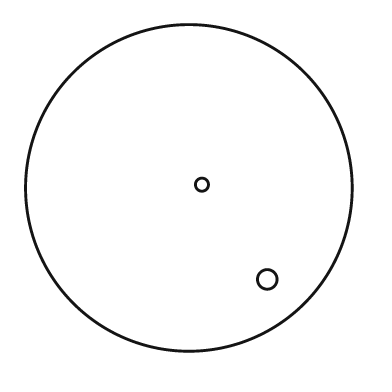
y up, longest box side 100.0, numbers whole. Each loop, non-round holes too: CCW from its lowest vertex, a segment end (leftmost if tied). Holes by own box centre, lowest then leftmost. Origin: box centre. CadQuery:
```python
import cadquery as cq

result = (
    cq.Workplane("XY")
    .moveTo(0.0, 0.0)
    .circle(50.0)
    .moveTo(24.0, -28.0)
    .circle(3.0)
    .moveTo(4.0, 1.0)
    .circle(2.0)
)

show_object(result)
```